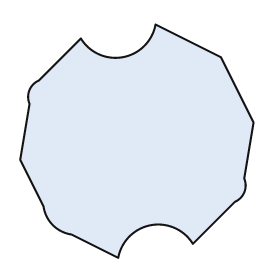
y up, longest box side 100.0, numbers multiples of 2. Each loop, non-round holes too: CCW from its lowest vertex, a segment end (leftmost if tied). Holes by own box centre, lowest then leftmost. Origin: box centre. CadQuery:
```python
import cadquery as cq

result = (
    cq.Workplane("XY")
    .moveTo(-8.0, -50.0)
    .threePointArc((6.0, -36.0), (24.0, -44.0))
    .lineTo(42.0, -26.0)
    .threePointArc((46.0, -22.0), (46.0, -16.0))
    .lineTo(50.0, 8.0)
    .lineTo(36.0, 36.0)
    .lineTo(8.0, 50.0)
    .threePointArc((-6.0, 36.0), (-24.0, 44.0))
    .lineTo(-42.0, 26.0)
    .threePointArc((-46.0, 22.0), (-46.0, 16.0))
    .lineTo(-50.0, -8.0)
    .lineTo(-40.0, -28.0)
    .threePointArc((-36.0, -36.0), (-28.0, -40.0))
    .close()
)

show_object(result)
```